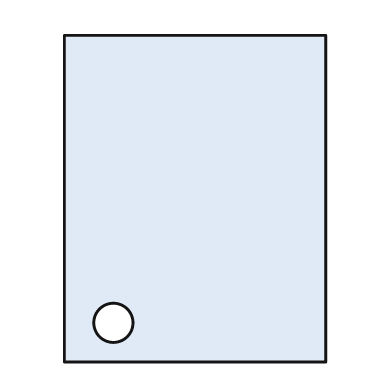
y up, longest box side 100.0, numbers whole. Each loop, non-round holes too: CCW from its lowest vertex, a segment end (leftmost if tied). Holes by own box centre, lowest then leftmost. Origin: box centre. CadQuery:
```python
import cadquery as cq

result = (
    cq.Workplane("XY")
    .moveTo(-40.0, -50.0)
    .lineTo(40.0, -50.0)
    .lineTo(40.0, 50.0)
    .lineTo(-40.0, 50.0)
    .close()
    .moveTo(-25.0, -38.0)
    .circle(6.0)
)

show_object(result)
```